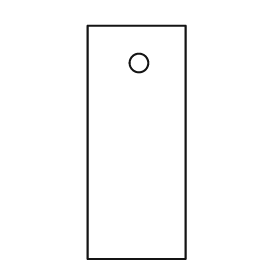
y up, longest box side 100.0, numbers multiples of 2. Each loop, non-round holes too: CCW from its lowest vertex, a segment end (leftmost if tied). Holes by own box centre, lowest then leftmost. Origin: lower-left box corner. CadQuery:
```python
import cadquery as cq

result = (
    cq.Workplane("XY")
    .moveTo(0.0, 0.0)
    .lineTo(42.0, 0.0)
    .lineTo(42.0, 100.0)
    .lineTo(0.0, 100.0)
    .close()
    .moveTo(22.0, 84.0)
    .circle(4.0)
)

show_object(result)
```